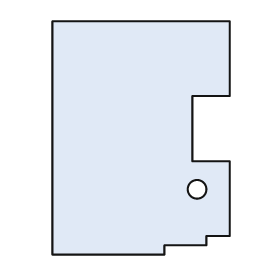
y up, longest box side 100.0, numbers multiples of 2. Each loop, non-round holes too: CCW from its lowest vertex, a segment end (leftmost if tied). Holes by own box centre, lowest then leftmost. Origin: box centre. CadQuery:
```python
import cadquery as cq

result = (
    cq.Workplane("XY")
    .moveTo(-38.0, -50.0)
    .lineTo(10.0, -50.0)
    .lineTo(10.0, -46.0)
    .lineTo(28.0, -46.0)
    .lineTo(28.0, -42.0)
    .lineTo(38.0, -42.0)
    .lineTo(38.0, -10.0)
    .lineTo(22.0, -10.0)
    .lineTo(22.0, 18.0)
    .lineTo(38.0, 18.0)
    .lineTo(38.0, 50.0)
    .lineTo(-38.0, 50.0)
    .close()
    .moveTo(24.0, -22.0)
    .circle(4.0)
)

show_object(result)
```